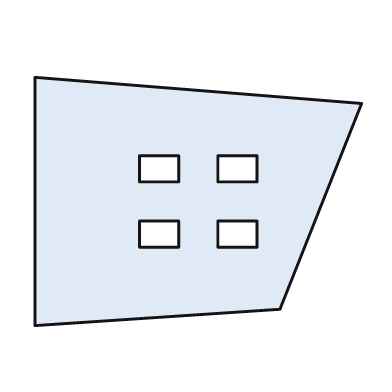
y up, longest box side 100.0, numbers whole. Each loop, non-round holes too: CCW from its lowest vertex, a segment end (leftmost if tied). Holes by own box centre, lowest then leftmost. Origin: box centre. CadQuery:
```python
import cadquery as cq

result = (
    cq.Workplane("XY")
    .moveTo(-50.0, -38.0)
    .lineTo(25.0, -33.0)
    .lineTo(50.0, 30.0)
    .lineTo(-50.0, 38.0)
    .close()
    .moveTo(-18.0, -14.0)
    .lineTo(-6.0, -14.0)
    .lineTo(-6.0, -6.0)
    .lineTo(-18.0, -6.0)
    .close()
    .moveTo(6.0, -14.0)
    .lineTo(18.0, -14.0)
    .lineTo(18.0, -6.0)
    .lineTo(6.0, -6.0)
    .close()
    .moveTo(-18.0, 6.0)
    .lineTo(-6.0, 6.0)
    .lineTo(-6.0, 14.0)
    .lineTo(-18.0, 14.0)
    .close()
    .moveTo(6.0, 6.0)
    .lineTo(18.0, 6.0)
    .lineTo(18.0, 14.0)
    .lineTo(6.0, 14.0)
    .close()
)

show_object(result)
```